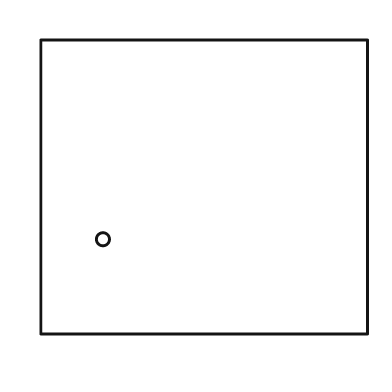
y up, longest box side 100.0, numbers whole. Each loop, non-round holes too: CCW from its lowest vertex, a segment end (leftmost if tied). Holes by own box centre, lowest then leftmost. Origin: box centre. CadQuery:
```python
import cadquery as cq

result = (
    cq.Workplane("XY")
    .moveTo(-50.0, -45.0)
    .lineTo(50.0, -45.0)
    .lineTo(50.0, 45.0)
    .lineTo(-50.0, 45.0)
    .close()
    .moveTo(-31.0, -16.0)
    .circle(2.0)
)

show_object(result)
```